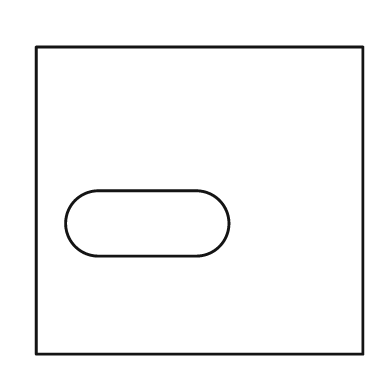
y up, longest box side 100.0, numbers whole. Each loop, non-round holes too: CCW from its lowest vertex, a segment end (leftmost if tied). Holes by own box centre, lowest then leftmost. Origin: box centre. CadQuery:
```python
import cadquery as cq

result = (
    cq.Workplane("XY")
    .moveTo(-50.0, -47.0)
    .lineTo(50.0, -47.0)
    .lineTo(50.0, 47.0)
    .lineTo(-50.0, 47.0)
    .close()
    .moveTo(-31.0, -17.0)
    .lineTo(-1.0, -17.0)
    .threePointArc((9.0, -7.0), (-1.0, 3.0))
    .lineTo(-31.0, 3.0)
    .threePointArc((-41.0, -7.0), (-31.0, -17.0))
    .close()
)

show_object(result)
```